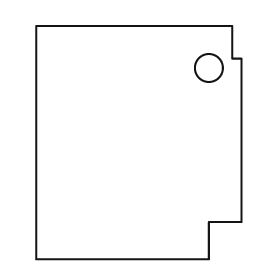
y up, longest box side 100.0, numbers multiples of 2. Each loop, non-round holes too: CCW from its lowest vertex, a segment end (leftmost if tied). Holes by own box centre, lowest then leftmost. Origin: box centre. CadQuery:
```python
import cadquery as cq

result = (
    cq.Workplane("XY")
    .moveTo(-44.0, -50.0)
    .lineTo(30.0, -50.0)
    .lineTo(30.0, -34.0)
    .lineTo(44.0, -34.0)
    .lineTo(44.0, 36.0)
    .lineTo(40.0, 36.0)
    .lineTo(40.0, 50.0)
    .lineTo(-44.0, 50.0)
    .close()
    .moveTo(30.0, 32.0)
    .circle(6.0)
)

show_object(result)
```